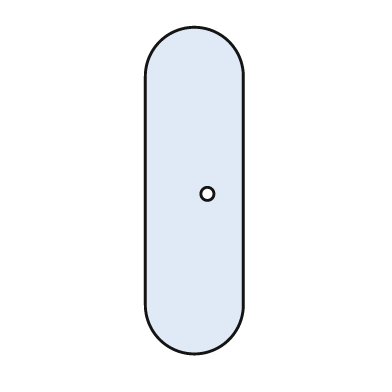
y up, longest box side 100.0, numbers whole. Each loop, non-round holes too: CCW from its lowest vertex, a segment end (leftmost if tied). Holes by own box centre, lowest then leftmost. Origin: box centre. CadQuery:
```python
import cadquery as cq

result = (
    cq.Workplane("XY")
    .moveTo(-15.0, -35.0)
    .threePointArc((0.0, -50.0), (15.0, -35.0))
    .lineTo(15.0, 35.0)
    .threePointArc((0.0, 50.0), (-15.0, 35.0))
    .close()
    .moveTo(4.0, -1.0)
    .circle(2.0)
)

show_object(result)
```